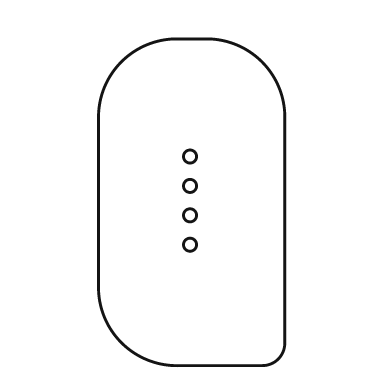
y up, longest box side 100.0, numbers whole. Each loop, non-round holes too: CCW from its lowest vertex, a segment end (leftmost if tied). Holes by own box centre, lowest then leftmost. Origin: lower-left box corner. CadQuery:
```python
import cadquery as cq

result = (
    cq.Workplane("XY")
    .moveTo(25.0, 0.0)
    .lineTo(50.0, 0.0)
    .threePointArc((55.0, 2.0), (57.0, 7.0))
    .lineTo(57.0, 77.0)
    .threePointArc((50.0, 93.0), (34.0, 100.0))
    .lineTo(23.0, 100.0)
    .threePointArc((7.0, 93.0), (0.0, 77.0))
    .lineTo(0.0, 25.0)
    .threePointArc((7.0, 7.0), (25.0, 0.0))
    .close()
    .moveTo(28.0, 37.0)
    .circle(2.0)
    .moveTo(28.0, 46.0)
    .circle(2.0)
    .moveTo(28.0, 55.0)
    .circle(2.0)
    .moveTo(28.0, 64.0)
    .circle(2.0)
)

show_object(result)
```